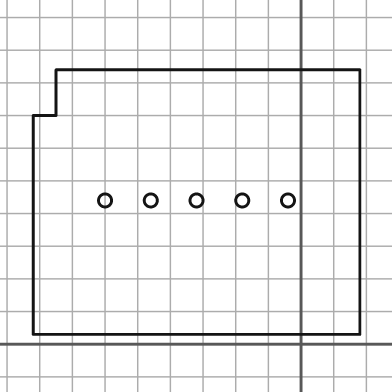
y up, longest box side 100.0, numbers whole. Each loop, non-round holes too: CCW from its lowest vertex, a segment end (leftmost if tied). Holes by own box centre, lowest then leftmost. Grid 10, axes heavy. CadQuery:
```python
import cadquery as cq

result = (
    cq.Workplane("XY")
    .moveTo(-82.0, 3.0)
    .lineTo(18.0, 3.0)
    .lineTo(18.0, 84.0)
    .lineTo(-75.0, 84.0)
    .lineTo(-75.0, 70.0)
    .lineTo(-82.0, 70.0)
    .close()
    .moveTo(-60.0, 44.0)
    .circle(2.0)
    .moveTo(-46.0, 44.0)
    .circle(2.0)
    .moveTo(-32.0, 44.0)
    .circle(2.0)
    .moveTo(-18.0, 44.0)
    .circle(2.0)
    .moveTo(-4.0, 44.0)
    .circle(2.0)
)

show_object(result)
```